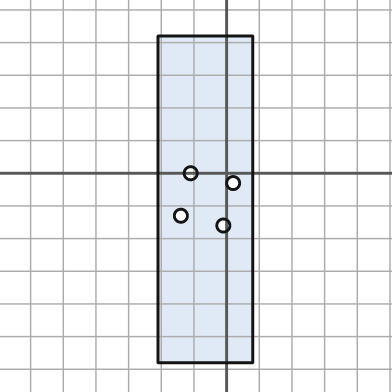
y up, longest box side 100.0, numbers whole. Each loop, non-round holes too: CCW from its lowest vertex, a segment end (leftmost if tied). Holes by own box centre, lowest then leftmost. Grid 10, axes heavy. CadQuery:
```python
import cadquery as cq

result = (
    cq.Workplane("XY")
    .moveTo(-21.0, -58.0)
    .lineTo(8.0, -58.0)
    .lineTo(8.0, 42.0)
    .lineTo(-21.0, 42.0)
    .close()
    .moveTo(-1.0, -16.0)
    .circle(2.0)
    .moveTo(-14.0, -13.0)
    .circle(2.0)
    .moveTo(2.0, -3.0)
    .circle(2.0)
    .moveTo(-11.0, 0.0)
    .circle(2.0)
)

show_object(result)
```